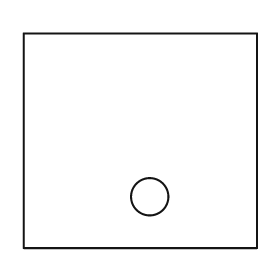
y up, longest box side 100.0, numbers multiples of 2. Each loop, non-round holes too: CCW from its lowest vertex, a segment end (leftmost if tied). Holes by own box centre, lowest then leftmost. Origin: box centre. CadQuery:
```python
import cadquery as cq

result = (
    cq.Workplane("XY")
    .moveTo(-50.0, -46.0)
    .lineTo(50.0, -46.0)
    .lineTo(50.0, 46.0)
    .lineTo(-50.0, 46.0)
    .close()
    .moveTo(4.0, -24.0)
    .circle(8.0)
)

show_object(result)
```